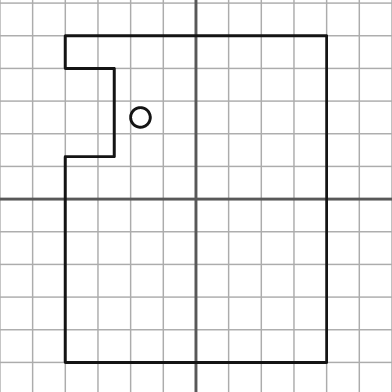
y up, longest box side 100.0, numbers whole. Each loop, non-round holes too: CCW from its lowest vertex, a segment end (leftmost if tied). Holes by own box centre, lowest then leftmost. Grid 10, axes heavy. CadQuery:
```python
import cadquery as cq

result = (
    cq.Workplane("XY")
    .moveTo(-40.0, -50.0)
    .lineTo(40.0, -50.0)
    .lineTo(40.0, 50.0)
    .lineTo(-40.0, 50.0)
    .lineTo(-40.0, 40.0)
    .lineTo(-25.0, 40.0)
    .lineTo(-25.0, 13.0)
    .lineTo(-40.0, 13.0)
    .close()
    .moveTo(-17.0, 25.0)
    .circle(3.0)
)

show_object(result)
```